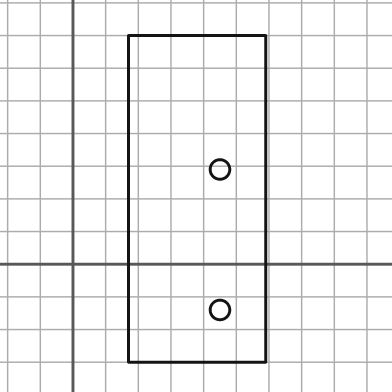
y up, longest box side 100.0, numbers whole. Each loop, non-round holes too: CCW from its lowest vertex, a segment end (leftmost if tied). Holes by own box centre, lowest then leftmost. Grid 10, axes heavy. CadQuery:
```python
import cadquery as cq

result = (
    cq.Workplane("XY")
    .moveTo(17.0, -30.0)
    .lineTo(59.0, -30.0)
    .lineTo(59.0, 70.0)
    .lineTo(17.0, 70.0)
    .close()
    .moveTo(45.0, -14.0)
    .circle(3.0)
    .moveTo(45.0, 29.0)
    .circle(3.0)
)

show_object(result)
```